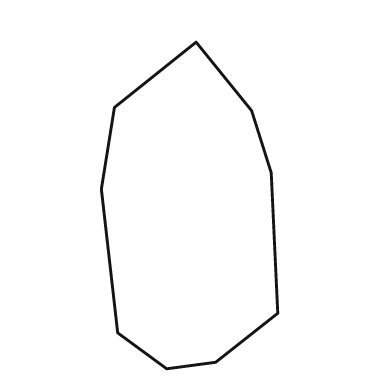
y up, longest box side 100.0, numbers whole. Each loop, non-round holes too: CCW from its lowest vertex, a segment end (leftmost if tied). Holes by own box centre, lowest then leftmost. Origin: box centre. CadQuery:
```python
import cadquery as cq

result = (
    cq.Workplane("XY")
    .moveTo(-7.0, -50.0)
    .lineTo(8.0, -48.0)
    .lineTo(27.0, -33.0)
    .lineTo(25.0, 10.0)
    .lineTo(19.0, 29.0)
    .lineTo(2.0, 50.0)
    .lineTo(-23.0, 30.0)
    .lineTo(-27.0, 5.0)
    .lineTo(-22.0, -39.0)
    .close()
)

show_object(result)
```